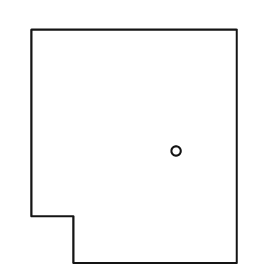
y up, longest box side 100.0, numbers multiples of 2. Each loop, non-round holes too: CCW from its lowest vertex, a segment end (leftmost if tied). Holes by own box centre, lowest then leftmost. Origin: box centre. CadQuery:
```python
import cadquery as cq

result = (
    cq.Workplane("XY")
    .moveTo(-26.0, -50.0)
    .lineTo(44.0, -50.0)
    .lineTo(44.0, 50.0)
    .lineTo(-44.0, 50.0)
    .lineTo(-44.0, -30.0)
    .lineTo(-26.0, -30.0)
    .close()
    .moveTo(18.0, -2.0)
    .circle(2.0)
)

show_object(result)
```